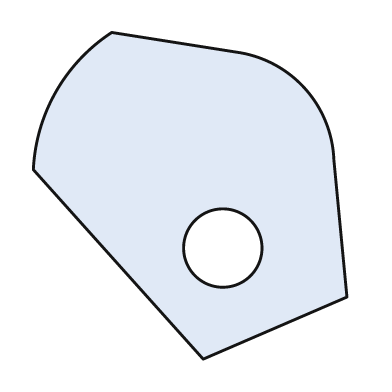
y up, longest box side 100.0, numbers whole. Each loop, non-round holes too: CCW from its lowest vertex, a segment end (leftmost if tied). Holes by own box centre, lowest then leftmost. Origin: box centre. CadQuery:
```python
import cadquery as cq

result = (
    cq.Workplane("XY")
    .moveTo(4.0, -50.0)
    .lineTo(48.0, -31.0)
    .lineTo(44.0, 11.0)
    .threePointArc((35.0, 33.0), (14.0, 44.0))
    .lineTo(-24.0, 50.0)
    .threePointArc((-41.0, 32.0), (-48.0, 8.0))
    .close()
    .moveTo(10.0, -16.0)
    .circle(12.0)
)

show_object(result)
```